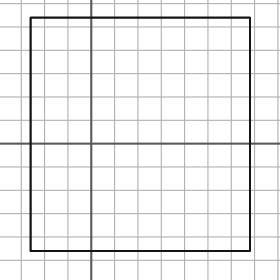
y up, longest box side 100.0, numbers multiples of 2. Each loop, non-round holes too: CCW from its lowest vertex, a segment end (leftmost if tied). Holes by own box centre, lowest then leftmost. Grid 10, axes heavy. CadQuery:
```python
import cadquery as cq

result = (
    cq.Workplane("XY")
    .moveTo(-26.0, -46.0)
    .lineTo(68.0, -46.0)
    .lineTo(68.0, 54.0)
    .lineTo(-26.0, 54.0)
    .close()
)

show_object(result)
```